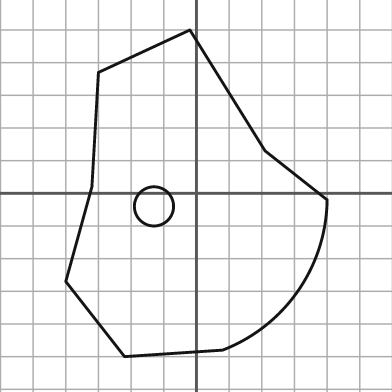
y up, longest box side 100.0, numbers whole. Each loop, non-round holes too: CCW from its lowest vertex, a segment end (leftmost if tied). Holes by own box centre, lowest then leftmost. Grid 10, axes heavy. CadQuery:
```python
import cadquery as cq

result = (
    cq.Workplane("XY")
    .moveTo(-22.0, -50.0)
    .lineTo(8.0, -48.0)
    .threePointArc((31.0, -30.0), (40.0, -2.0))
    .lineTo(21.0, 13.0)
    .lineTo(-2.0, 50.0)
    .lineTo(-30.0, 37.0)
    .lineTo(-32.0, 2.0)
    .lineTo(-40.0, -27.0)
    .close()
    .moveTo(-13.0, -4.0)
    .circle(6.0)
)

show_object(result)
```